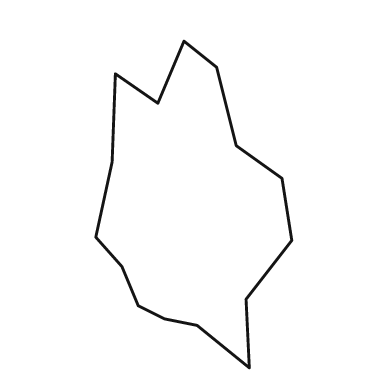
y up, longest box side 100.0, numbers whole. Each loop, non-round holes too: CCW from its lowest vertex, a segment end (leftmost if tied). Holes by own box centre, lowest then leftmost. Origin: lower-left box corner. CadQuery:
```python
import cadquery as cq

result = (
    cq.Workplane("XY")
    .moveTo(47.0, 0.0)
    .lineTo(46.0, 21.0)
    .lineTo(60.0, 39.0)
    .lineTo(57.0, 58.0)
    .lineTo(43.0, 68.0)
    .lineTo(37.0, 92.0)
    .lineTo(27.0, 100.0)
    .lineTo(19.0, 81.0)
    .lineTo(6.0, 90.0)
    .lineTo(5.0, 63.0)
    .lineTo(0.0, 40.0)
    .lineTo(8.0, 31.0)
    .lineTo(13.0, 19.0)
    .lineTo(21.0, 15.0)
    .lineTo(31.0, 13.0)
    .close()
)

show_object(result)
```